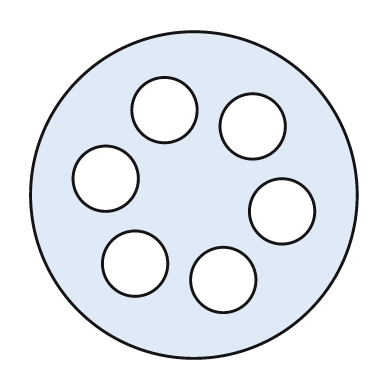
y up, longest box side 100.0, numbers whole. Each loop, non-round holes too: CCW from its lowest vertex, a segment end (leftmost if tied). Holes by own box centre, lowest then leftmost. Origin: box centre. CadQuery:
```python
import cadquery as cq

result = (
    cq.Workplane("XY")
    .moveTo(0.0, 0.0)
    .circle(50.0)
    .moveTo(9.0, -26.0)
    .circle(10.0)
    .moveTo(-18.0, -21.0)
    .circle(10.0)
    .moveTo(27.0, -5.0)
    .circle(10.0)
    .moveTo(-27.0, 5.0)
    .circle(10.0)
    .moveTo(18.0, 21.0)
    .circle(10.0)
    .moveTo(-9.0, 26.0)
    .circle(10.0)
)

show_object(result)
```